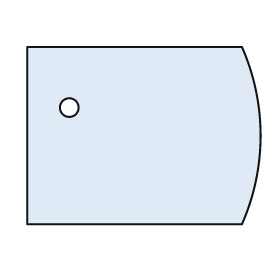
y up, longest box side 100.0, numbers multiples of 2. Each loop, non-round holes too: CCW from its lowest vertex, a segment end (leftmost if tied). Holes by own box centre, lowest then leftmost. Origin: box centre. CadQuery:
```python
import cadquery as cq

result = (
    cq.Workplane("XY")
    .moveTo(-50.0, -38.0)
    .lineTo(42.0, -38.0)
    .threePointArc((50.0, 0.0), (42.0, 38.0))
    .lineTo(-50.0, 38.0)
    .close()
    .moveTo(-32.0, 12.0)
    .circle(4.0)
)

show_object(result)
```